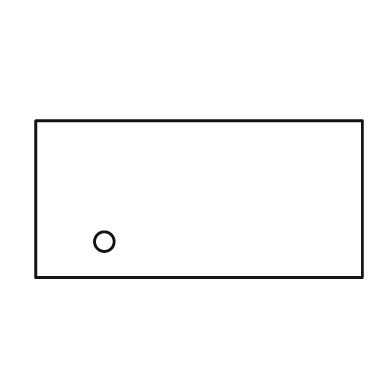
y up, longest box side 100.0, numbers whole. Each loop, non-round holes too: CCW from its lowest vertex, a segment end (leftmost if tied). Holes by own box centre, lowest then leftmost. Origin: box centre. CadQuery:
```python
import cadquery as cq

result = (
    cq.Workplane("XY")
    .moveTo(-50.0, -24.0)
    .lineTo(50.0, -24.0)
    .lineTo(50.0, 24.0)
    .lineTo(-50.0, 24.0)
    .close()
    .moveTo(-29.0, -13.0)
    .circle(3.0)
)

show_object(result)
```